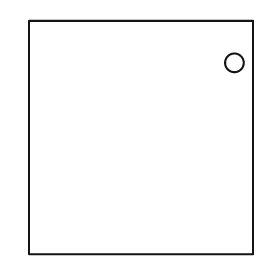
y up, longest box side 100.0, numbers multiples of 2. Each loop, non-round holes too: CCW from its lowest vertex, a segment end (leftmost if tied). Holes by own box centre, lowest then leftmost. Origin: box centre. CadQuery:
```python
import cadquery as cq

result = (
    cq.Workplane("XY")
    .moveTo(-48.0, -50.0)
    .lineTo(48.0, -50.0)
    .lineTo(48.0, 50.0)
    .lineTo(-48.0, 50.0)
    .close()
    .moveTo(40.0, 32.0)
    .circle(4.0)
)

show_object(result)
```